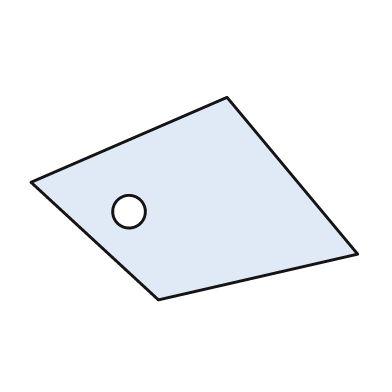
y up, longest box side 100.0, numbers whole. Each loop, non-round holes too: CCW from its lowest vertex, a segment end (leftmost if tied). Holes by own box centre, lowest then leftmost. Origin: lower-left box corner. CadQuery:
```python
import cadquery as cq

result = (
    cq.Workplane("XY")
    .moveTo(39.0, 0.0)
    .lineTo(100.0, 14.0)
    .lineTo(60.0, 62.0)
    .lineTo(0.0, 36.0)
    .close()
    .moveTo(30.0, 27.0)
    .circle(5.0)
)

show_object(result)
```